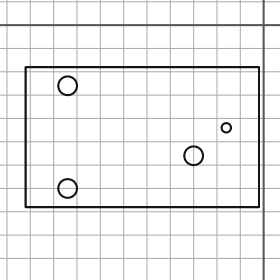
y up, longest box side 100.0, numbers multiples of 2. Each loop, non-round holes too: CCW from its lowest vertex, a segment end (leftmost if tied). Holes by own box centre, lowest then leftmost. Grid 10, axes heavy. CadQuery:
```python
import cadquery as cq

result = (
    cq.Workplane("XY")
    .moveTo(-102.0, -78.0)
    .lineTo(-2.0, -78.0)
    .lineTo(-2.0, -18.0)
    .lineTo(-102.0, -18.0)
    .close()
    .moveTo(-84.0, -70.0)
    .circle(4.0)
    .moveTo(-30.0, -56.0)
    .circle(4.0)
    .moveTo(-16.0, -44.0)
    .circle(2.0)
    .moveTo(-84.0, -26.0)
    .circle(4.0)
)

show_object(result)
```